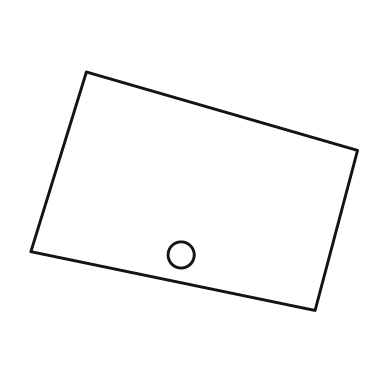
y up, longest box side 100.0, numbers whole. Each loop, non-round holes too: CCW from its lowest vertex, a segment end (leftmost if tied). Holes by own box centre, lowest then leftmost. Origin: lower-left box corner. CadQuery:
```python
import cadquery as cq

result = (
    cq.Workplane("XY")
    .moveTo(87.0, 0.0)
    .lineTo(100.0, 49.0)
    .lineTo(17.0, 73.0)
    .lineTo(0.0, 18.0)
    .close()
    .moveTo(46.0, 17.0)
    .circle(4.0)
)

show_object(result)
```